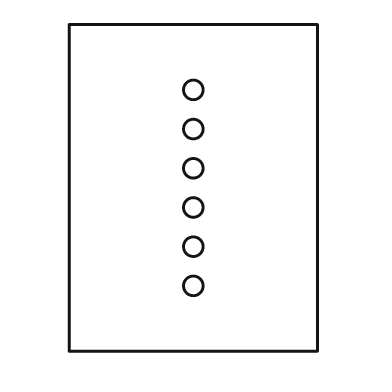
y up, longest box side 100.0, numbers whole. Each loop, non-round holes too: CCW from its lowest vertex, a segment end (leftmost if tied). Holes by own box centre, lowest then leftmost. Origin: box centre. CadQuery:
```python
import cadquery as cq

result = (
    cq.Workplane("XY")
    .moveTo(-38.0, -50.0)
    .lineTo(38.0, -50.0)
    .lineTo(38.0, 50.0)
    .lineTo(-38.0, 50.0)
    .close()
    .moveTo(0.0, -30.0)
    .circle(3.0)
    .moveTo(0.0, -18.0)
    .circle(3.0)
    .moveTo(0.0, -6.0)
    .circle(3.0)
    .moveTo(0.0, 6.0)
    .circle(3.0)
    .moveTo(0.0, 18.0)
    .circle(3.0)
    .moveTo(0.0, 30.0)
    .circle(3.0)
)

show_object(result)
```